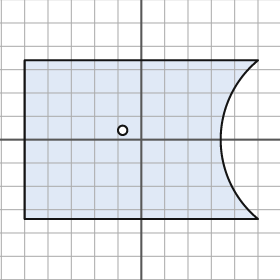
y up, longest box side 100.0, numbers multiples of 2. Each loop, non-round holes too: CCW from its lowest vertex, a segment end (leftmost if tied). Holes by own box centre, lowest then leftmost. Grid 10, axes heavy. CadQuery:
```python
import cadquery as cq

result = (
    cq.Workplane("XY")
    .moveTo(-50.0, -34.0)
    .lineTo(50.0, -34.0)
    .threePointArc((34.0, 0.0), (50.0, 34.0))
    .lineTo(-50.0, 34.0)
    .close()
    .moveTo(-8.0, 4.0)
    .circle(2.0)
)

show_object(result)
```